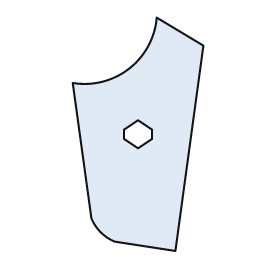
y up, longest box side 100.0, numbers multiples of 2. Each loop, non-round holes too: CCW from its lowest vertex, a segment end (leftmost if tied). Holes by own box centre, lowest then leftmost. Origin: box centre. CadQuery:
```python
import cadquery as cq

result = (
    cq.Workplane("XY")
    .moveTo(16.0, -50.0)
    .lineTo(28.0, 38.0)
    .lineTo(8.0, 50.0)
    .threePointArc((-4.0, 28.0), (-28.0, 22.0))
    .lineTo(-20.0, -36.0)
    .threePointArc((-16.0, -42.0), (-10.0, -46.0))
    .close()
    .moveTo(0.0, -6.0)
    .lineTo(6.0, -2.0)
    .lineTo(6.0, 2.0)
    .lineTo(0.0, 6.0)
    .lineTo(-6.0, 2.0)
    .lineTo(-6.0, -2.0)
    .close()
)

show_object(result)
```